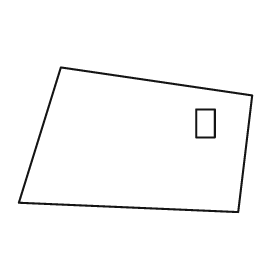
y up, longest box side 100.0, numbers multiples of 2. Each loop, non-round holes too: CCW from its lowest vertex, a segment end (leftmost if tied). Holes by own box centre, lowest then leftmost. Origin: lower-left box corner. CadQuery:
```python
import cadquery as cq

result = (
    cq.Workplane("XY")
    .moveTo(94.0, 0.0)
    .lineTo(100.0, 50.0)
    .lineTo(18.0, 62.0)
    .lineTo(0.0, 4.0)
    .close()
    .moveTo(76.0, 32.0)
    .lineTo(84.0, 32.0)
    .lineTo(84.0, 44.0)
    .lineTo(76.0, 44.0)
    .close()
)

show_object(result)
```